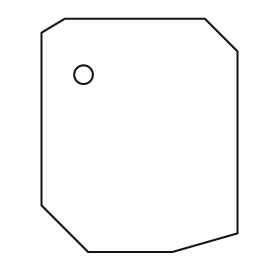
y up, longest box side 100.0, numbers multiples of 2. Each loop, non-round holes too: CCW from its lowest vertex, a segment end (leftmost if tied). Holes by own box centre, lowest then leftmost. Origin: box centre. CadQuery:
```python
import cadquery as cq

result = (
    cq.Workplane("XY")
    .moveTo(-22.0, -50.0)
    .lineTo(14.0, -50.0)
    .lineTo(42.0, -42.0)
    .lineTo(42.0, 36.0)
    .lineTo(28.0, 50.0)
    .lineTo(-32.0, 50.0)
    .lineTo(-42.0, 44.0)
    .lineTo(-42.0, -30.0)
    .close()
    .moveTo(-24.0, 26.0)
    .circle(4.0)
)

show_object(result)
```